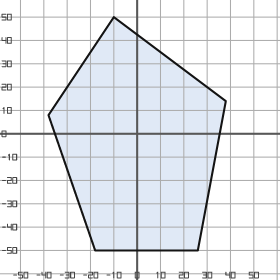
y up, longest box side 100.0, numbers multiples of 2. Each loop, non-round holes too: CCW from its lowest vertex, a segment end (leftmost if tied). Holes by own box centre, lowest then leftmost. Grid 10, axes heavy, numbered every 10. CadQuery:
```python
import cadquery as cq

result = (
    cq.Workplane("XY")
    .moveTo(-18.0, -50.0)
    .lineTo(26.0, -50.0)
    .lineTo(38.0, 14.0)
    .lineTo(-10.0, 50.0)
    .lineTo(-38.0, 8.0)
    .close()
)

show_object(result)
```